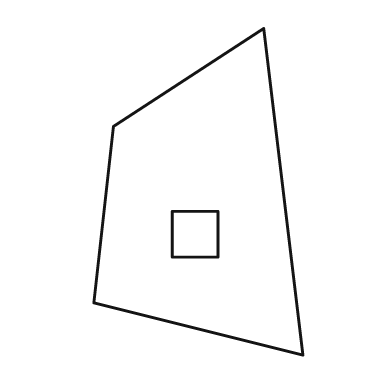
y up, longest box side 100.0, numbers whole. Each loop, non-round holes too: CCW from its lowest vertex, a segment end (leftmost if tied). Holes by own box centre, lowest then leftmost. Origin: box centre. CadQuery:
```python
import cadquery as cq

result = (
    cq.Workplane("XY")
    .moveTo(32.0, -50.0)
    .lineTo(20.0, 50.0)
    .lineTo(-26.0, 20.0)
    .lineTo(-32.0, -34.0)
    .close()
    .moveTo(-8.0, -20.0)
    .lineTo(6.0, -20.0)
    .lineTo(6.0, -6.0)
    .lineTo(-8.0, -6.0)
    .close()
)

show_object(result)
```